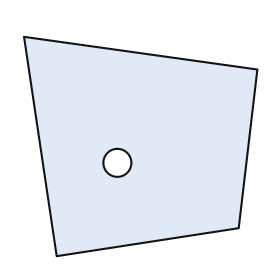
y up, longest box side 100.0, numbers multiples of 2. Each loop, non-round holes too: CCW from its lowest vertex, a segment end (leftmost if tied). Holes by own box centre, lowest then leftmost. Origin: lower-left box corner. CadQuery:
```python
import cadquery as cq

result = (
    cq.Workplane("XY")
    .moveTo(14.0, 0.0)
    .lineTo(92.0, 12.0)
    .lineTo(100.0, 80.0)
    .lineTo(0.0, 94.0)
    .close()
    .moveTo(40.0, 40.0)
    .circle(6.0)
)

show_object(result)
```